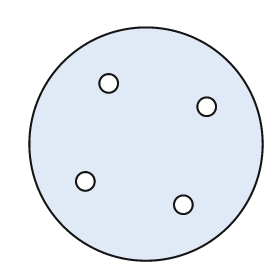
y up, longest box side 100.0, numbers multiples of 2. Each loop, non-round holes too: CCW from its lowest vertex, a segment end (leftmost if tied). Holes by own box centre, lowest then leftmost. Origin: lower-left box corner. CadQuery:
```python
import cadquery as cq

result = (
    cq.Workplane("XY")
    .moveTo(50.0, 50.0)
    .circle(50.0)
    .moveTo(66.0, 24.0)
    .circle(4.0)
    .moveTo(24.0, 34.0)
    .circle(4.0)
    .moveTo(76.0, 66.0)
    .circle(4.0)
    .moveTo(34.0, 76.0)
    .circle(4.0)
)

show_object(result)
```